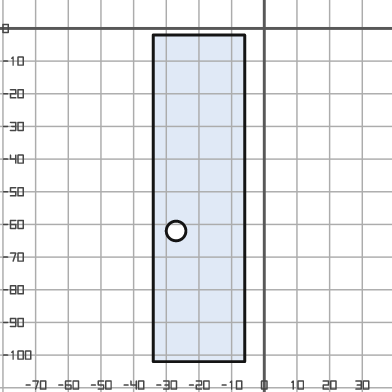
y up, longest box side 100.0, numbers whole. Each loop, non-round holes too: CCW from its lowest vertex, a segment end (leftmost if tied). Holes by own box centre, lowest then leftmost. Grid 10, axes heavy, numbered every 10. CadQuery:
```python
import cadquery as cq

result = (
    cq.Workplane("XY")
    .moveTo(-34.0, -102.0)
    .lineTo(-6.0, -102.0)
    .lineTo(-6.0, -2.0)
    .lineTo(-34.0, -2.0)
    .close()
    .moveTo(-27.0, -62.0)
    .circle(3.0)
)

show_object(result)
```